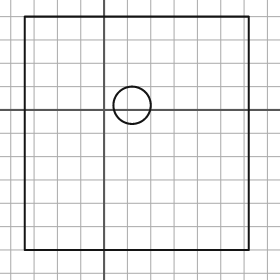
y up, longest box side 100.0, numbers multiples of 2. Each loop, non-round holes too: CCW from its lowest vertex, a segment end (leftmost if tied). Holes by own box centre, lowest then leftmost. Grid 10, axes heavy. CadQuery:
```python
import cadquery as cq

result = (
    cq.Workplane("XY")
    .moveTo(-34.0, -60.0)
    .lineTo(62.0, -60.0)
    .lineTo(62.0, 40.0)
    .lineTo(-34.0, 40.0)
    .close()
    .moveTo(12.0, 2.0)
    .circle(8.0)
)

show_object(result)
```